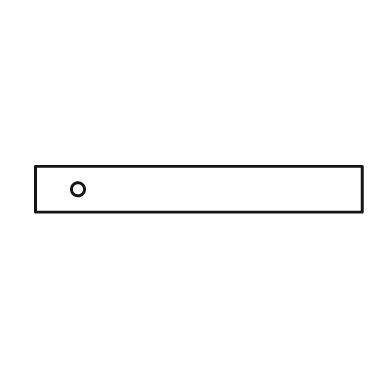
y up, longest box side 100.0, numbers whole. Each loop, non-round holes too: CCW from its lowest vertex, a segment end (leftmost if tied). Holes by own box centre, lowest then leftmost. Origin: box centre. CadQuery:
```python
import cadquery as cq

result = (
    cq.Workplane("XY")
    .moveTo(-50.0, -7.0)
    .lineTo(50.0, -7.0)
    .lineTo(50.0, 7.0)
    .lineTo(-50.0, 7.0)
    .close()
    .moveTo(-37.0, 0.0)
    .circle(2.0)
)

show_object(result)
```